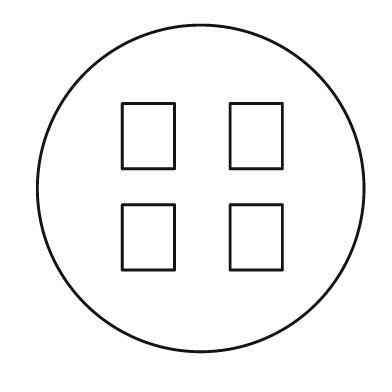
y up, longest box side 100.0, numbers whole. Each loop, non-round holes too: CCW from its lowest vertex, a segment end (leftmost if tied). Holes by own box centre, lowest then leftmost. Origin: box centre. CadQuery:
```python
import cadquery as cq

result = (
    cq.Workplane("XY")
    .moveTo(0.0, 0.0)
    .circle(50.0)
    .moveTo(-24.0, -25.0)
    .lineTo(-8.0, -25.0)
    .lineTo(-8.0, -5.0)
    .lineTo(-24.0, -5.0)
    .close()
    .moveTo(9.0, -25.0)
    .lineTo(25.0, -25.0)
    .lineTo(25.0, -5.0)
    .lineTo(9.0, -5.0)
    .close()
    .moveTo(-24.0, 6.0)
    .lineTo(-8.0, 6.0)
    .lineTo(-8.0, 26.0)
    .lineTo(-24.0, 26.0)
    .close()
    .moveTo(9.0, 6.0)
    .lineTo(25.0, 6.0)
    .lineTo(25.0, 26.0)
    .lineTo(9.0, 26.0)
    .close()
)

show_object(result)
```